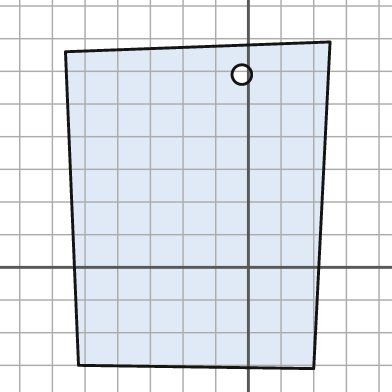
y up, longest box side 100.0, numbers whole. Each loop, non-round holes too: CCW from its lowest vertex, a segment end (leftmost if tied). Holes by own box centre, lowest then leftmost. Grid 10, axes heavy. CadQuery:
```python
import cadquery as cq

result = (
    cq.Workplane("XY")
    .moveTo(20.0, -31.0)
    .lineTo(25.0, 69.0)
    .lineTo(-56.0, 66.0)
    .lineTo(-52.0, -30.0)
    .close()
    .moveTo(-2.0, 59.0)
    .circle(3.0)
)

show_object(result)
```